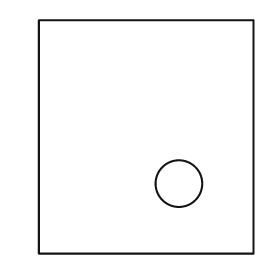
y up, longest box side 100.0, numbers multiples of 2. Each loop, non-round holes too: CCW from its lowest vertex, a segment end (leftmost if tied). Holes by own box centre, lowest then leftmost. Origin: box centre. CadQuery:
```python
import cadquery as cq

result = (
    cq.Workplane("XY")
    .moveTo(-46.0, -50.0)
    .lineTo(46.0, -50.0)
    .lineTo(46.0, 50.0)
    .lineTo(-46.0, 50.0)
    .close()
    .moveTo(14.0, -20.0)
    .circle(10.0)
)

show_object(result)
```